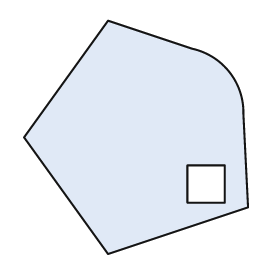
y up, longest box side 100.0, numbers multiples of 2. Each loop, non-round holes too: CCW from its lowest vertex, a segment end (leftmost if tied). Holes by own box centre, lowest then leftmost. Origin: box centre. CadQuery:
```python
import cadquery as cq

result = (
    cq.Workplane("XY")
    .moveTo(-12.0, -50.0)
    .lineTo(48.0, -30.0)
    .lineTo(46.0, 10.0)
    .threePointArc((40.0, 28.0), (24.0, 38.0))
    .lineTo(-12.0, 50.0)
    .lineTo(-48.0, 0.0)
    .close()
    .moveTo(22.0, -28.0)
    .lineTo(38.0, -28.0)
    .lineTo(38.0, -12.0)
    .lineTo(22.0, -12.0)
    .close()
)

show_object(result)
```